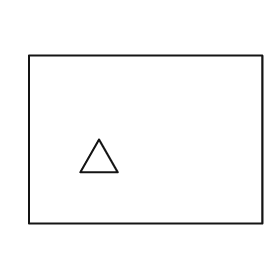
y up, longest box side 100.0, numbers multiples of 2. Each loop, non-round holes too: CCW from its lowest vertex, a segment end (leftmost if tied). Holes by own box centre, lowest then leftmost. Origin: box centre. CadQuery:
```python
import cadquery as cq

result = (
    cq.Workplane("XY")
    .moveTo(-50.0, -36.0)
    .lineTo(50.0, -36.0)
    .lineTo(50.0, 36.0)
    .lineTo(-50.0, 36.0)
    .close()
    .moveTo(-28.0, -14.0)
    .lineTo(-12.0, -14.0)
    .lineTo(-20.0, 0.0)
    .close()
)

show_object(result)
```